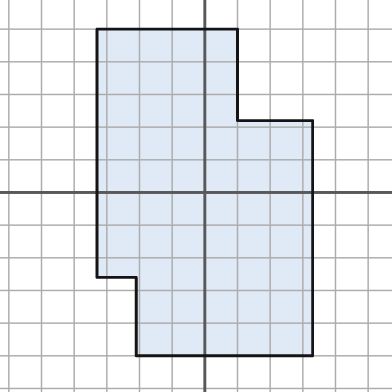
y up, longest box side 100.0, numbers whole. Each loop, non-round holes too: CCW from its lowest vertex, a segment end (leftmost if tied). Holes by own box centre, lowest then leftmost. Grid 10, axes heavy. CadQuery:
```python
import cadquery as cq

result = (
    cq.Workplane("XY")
    .moveTo(-21.0, -50.0)
    .lineTo(33.0, -50.0)
    .lineTo(33.0, 22.0)
    .lineTo(10.0, 22.0)
    .lineTo(10.0, 50.0)
    .lineTo(-33.0, 50.0)
    .lineTo(-33.0, -26.0)
    .lineTo(-21.0, -26.0)
    .close()
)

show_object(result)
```